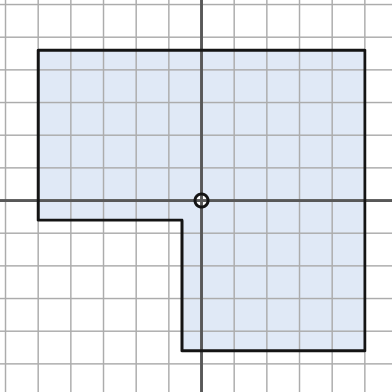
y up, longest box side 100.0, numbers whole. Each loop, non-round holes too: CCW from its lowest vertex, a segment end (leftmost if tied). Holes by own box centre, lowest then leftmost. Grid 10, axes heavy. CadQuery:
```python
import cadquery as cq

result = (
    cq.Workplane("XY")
    .moveTo(-6.0, -46.0)
    .lineTo(50.0, -46.0)
    .lineTo(50.0, 46.0)
    .lineTo(-50.0, 46.0)
    .lineTo(-50.0, -6.0)
    .lineTo(-6.0, -6.0)
    .close()
    .moveTo(0.0, 0.0)
    .circle(2.0)
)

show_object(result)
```